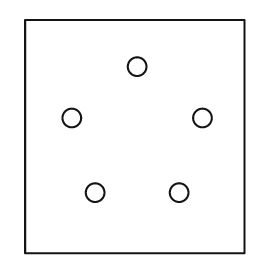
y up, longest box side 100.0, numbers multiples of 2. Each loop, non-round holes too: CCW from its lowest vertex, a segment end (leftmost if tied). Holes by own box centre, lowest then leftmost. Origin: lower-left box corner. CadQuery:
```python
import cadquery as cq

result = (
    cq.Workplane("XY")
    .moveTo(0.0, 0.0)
    .lineTo(94.0, 0.0)
    .lineTo(94.0, 100.0)
    .lineTo(0.0, 100.0)
    .close()
    .moveTo(30.0, 26.0)
    .circle(4.0)
    .moveTo(66.0, 26.0)
    .circle(4.0)
    .moveTo(20.0, 58.0)
    .circle(4.0)
    .moveTo(76.0, 58.0)
    .circle(4.0)
    .moveTo(48.0, 80.0)
    .circle(4.0)
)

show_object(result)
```